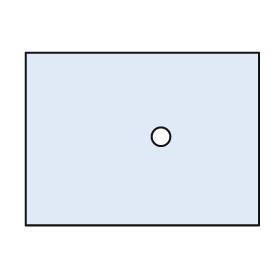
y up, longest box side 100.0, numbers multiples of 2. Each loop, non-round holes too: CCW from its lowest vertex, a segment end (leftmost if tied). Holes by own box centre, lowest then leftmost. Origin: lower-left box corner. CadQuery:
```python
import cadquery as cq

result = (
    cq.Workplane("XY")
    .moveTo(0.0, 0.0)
    .lineTo(100.0, 0.0)
    .lineTo(100.0, 74.0)
    .lineTo(0.0, 74.0)
    .close()
    .moveTo(58.0, 38.0)
    .circle(4.0)
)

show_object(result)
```